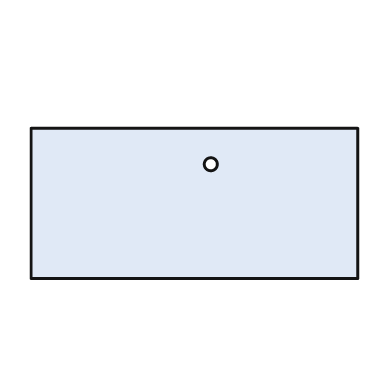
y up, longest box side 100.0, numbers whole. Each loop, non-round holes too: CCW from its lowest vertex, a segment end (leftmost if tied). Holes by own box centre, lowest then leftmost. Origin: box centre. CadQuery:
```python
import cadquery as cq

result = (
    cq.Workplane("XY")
    .moveTo(-50.0, -23.0)
    .lineTo(50.0, -23.0)
    .lineTo(50.0, 23.0)
    .lineTo(-50.0, 23.0)
    .close()
    .moveTo(5.0, 12.0)
    .circle(2.0)
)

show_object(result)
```